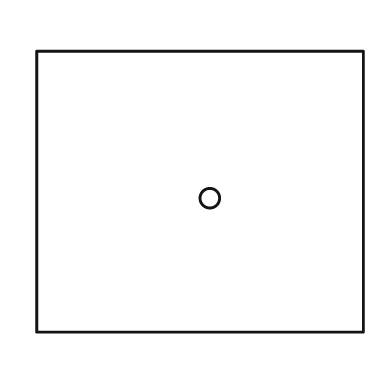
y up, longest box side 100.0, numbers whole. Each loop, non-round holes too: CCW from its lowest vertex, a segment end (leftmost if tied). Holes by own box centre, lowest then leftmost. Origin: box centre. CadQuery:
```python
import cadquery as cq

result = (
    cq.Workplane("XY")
    .moveTo(-50.0, -43.0)
    .lineTo(50.0, -43.0)
    .lineTo(50.0, 43.0)
    .lineTo(-50.0, 43.0)
    .close()
    .moveTo(3.0, -2.0)
    .circle(3.0)
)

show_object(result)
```